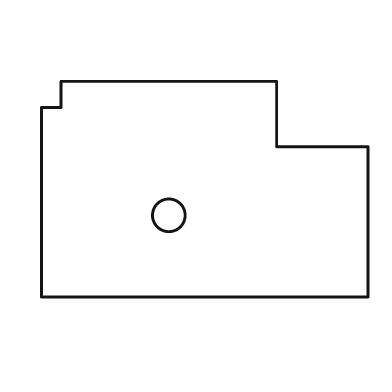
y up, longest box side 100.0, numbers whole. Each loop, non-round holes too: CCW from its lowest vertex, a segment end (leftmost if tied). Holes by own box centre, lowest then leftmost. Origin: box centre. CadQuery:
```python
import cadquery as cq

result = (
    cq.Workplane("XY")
    .moveTo(-50.0, -33.0)
    .lineTo(50.0, -33.0)
    .lineTo(50.0, 13.0)
    .lineTo(22.0, 13.0)
    .lineTo(22.0, 33.0)
    .lineTo(-44.0, 33.0)
    .lineTo(-44.0, 25.0)
    .lineTo(-50.0, 25.0)
    .close()
    .moveTo(-11.0, -8.0)
    .circle(5.0)
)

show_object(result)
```